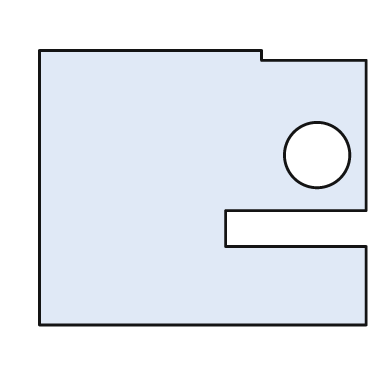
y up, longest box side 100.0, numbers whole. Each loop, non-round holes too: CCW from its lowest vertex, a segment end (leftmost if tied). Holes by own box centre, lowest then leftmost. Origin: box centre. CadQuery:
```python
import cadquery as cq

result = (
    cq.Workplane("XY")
    .moveTo(-50.0, -42.0)
    .lineTo(50.0, -42.0)
    .lineTo(50.0, -18.0)
    .lineTo(7.0, -18.0)
    .lineTo(7.0, -7.0)
    .lineTo(50.0, -7.0)
    .lineTo(50.0, 39.0)
    .lineTo(18.0, 39.0)
    .lineTo(18.0, 42.0)
    .lineTo(-50.0, 42.0)
    .close()
    .moveTo(35.0, 10.0)
    .circle(10.0)
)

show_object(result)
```